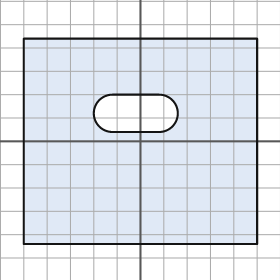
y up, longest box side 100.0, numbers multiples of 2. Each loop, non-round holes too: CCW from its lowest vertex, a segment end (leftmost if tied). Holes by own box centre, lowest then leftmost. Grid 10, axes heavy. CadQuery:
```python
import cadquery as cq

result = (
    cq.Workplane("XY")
    .moveTo(-50.0, -44.0)
    .lineTo(50.0, -44.0)
    .lineTo(50.0, 44.0)
    .lineTo(-50.0, 44.0)
    .close()
    .moveTo(-12.0, 4.0)
    .lineTo(8.0, 4.0)
    .threePointArc((16.0, 12.0), (8.0, 20.0))
    .lineTo(-12.0, 20.0)
    .threePointArc((-20.0, 12.0), (-12.0, 4.0))
    .close()
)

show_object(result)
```